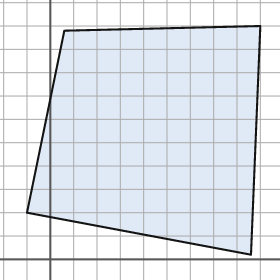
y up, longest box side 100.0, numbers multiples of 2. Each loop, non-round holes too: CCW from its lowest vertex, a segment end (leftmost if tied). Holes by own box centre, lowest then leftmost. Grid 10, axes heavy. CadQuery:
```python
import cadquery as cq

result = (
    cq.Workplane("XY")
    .moveTo(86.0, 2.0)
    .lineTo(90.0, 100.0)
    .lineTo(6.0, 98.0)
    .lineTo(-10.0, 20.0)
    .close()
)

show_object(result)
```